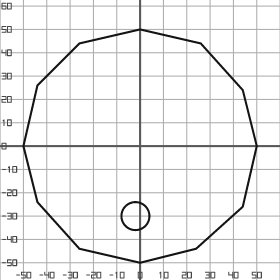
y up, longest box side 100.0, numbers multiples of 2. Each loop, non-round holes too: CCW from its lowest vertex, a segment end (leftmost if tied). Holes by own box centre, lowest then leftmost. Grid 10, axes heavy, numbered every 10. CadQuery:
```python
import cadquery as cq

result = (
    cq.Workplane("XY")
    .moveTo(0.0, -50.0)
    .lineTo(24.0, -44.0)
    .lineTo(44.0, -26.0)
    .lineTo(50.0, 0.0)
    .lineTo(44.0, 24.0)
    .lineTo(26.0, 44.0)
    .lineTo(0.0, 50.0)
    .lineTo(-26.0, 44.0)
    .lineTo(-44.0, 26.0)
    .lineTo(-50.0, 0.0)
    .lineTo(-44.0, -24.0)
    .lineTo(-26.0, -44.0)
    .close()
    .moveTo(-2.0, -30.0)
    .circle(6.0)
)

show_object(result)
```